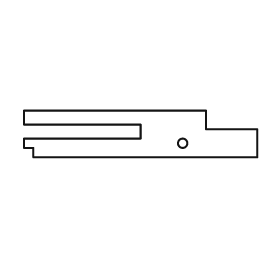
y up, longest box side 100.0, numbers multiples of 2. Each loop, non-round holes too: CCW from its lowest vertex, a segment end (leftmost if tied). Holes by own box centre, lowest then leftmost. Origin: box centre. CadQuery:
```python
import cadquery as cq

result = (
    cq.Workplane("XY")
    .moveTo(-46.0, -10.0)
    .lineTo(50.0, -10.0)
    .lineTo(50.0, 2.0)
    .lineTo(28.0, 2.0)
    .lineTo(28.0, 10.0)
    .lineTo(-50.0, 10.0)
    .lineTo(-50.0, 4.0)
    .lineTo(0.0, 4.0)
    .lineTo(0.0, -2.0)
    .lineTo(-50.0, -2.0)
    .lineTo(-50.0, -6.0)
    .lineTo(-46.0, -6.0)
    .close()
    .moveTo(18.0, -4.0)
    .circle(2.0)
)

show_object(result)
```